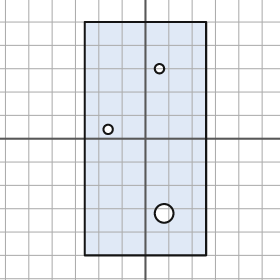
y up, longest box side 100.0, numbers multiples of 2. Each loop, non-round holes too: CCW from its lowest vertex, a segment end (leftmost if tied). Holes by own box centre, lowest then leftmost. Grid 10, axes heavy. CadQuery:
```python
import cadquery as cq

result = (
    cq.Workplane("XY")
    .moveTo(-26.0, -50.0)
    .lineTo(26.0, -50.0)
    .lineTo(26.0, 50.0)
    .lineTo(-26.0, 50.0)
    .close()
    .moveTo(8.0, -32.0)
    .circle(4.0)
    .moveTo(-16.0, 4.0)
    .circle(2.0)
    .moveTo(6.0, 30.0)
    .circle(2.0)
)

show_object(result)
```